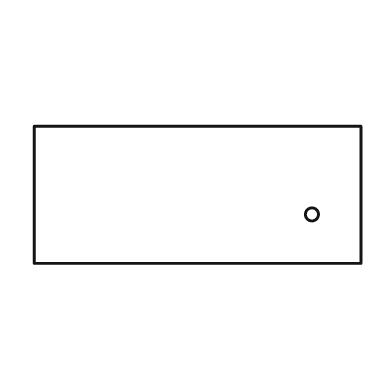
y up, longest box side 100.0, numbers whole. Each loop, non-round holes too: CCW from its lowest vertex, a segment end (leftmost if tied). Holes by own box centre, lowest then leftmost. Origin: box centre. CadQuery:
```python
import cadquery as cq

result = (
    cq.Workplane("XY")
    .moveTo(-50.0, -21.0)
    .lineTo(50.0, -21.0)
    .lineTo(50.0, 21.0)
    .lineTo(-50.0, 21.0)
    .close()
    .moveTo(35.0, -6.0)
    .circle(2.0)
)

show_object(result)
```